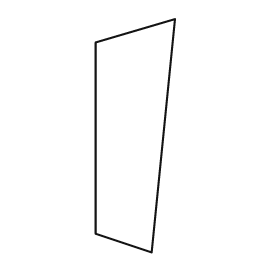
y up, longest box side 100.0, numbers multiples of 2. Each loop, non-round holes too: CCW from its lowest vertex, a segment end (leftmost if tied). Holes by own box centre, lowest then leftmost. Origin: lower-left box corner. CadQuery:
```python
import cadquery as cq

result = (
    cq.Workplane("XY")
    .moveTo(24.0, 0.0)
    .lineTo(34.0, 100.0)
    .lineTo(0.0, 90.0)
    .lineTo(0.0, 8.0)
    .close()
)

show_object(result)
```